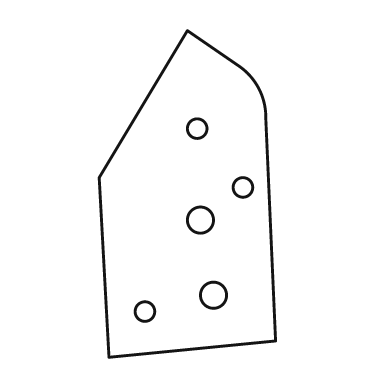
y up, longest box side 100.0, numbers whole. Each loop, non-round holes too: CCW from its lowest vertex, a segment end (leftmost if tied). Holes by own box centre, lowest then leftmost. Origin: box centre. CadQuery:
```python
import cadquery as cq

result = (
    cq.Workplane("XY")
    .moveTo(-24.0, -50.0)
    .lineTo(27.0, -45.0)
    .lineTo(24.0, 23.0)
    .threePointArc((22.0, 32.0), (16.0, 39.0))
    .lineTo(0.0, 50.0)
    .lineTo(-27.0, 5.0)
    .close()
    .moveTo(-13.0, -36.0)
    .circle(3.0)
    .moveTo(8.0, -31.0)
    .circle(4.0)
    .moveTo(4.0, -8.0)
    .circle(4.0)
    .moveTo(17.0, 2.0)
    .circle(3.0)
    .moveTo(3.0, 20.0)
    .circle(3.0)
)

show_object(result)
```